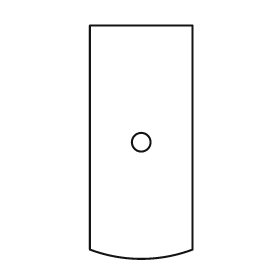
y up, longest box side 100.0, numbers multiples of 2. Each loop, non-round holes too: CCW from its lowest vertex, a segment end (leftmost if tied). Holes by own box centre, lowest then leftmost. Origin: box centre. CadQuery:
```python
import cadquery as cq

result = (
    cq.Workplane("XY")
    .moveTo(-22.0, -46.0)
    .threePointArc((0.0, -50.0), (22.0, -46.0))
    .lineTo(22.0, 50.0)
    .lineTo(-22.0, 50.0)
    .close()
    .moveTo(0.0, 0.0)
    .circle(4.0)
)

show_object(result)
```